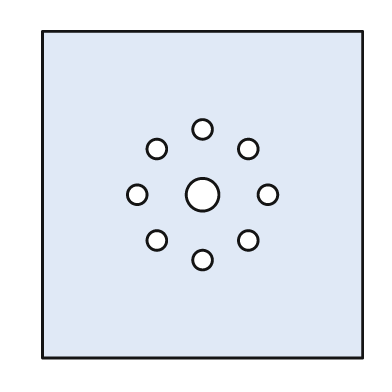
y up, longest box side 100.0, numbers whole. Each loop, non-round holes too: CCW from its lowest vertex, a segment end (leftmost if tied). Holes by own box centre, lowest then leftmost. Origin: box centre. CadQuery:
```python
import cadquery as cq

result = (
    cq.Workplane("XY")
    .moveTo(-49.0, -50.0)
    .lineTo(49.0, -50.0)
    .lineTo(49.0, 50.0)
    .lineTo(-49.0, 50.0)
    .close()
    .moveTo(0.0, -20.0)
    .circle(3.0)
    .moveTo(-14.0, -14.0)
    .circle(3.0)
    .moveTo(14.0, -14.0)
    .circle(3.0)
    .moveTo(-20.0, 0.0)
    .circle(3.0)
    .moveTo(0.0, 0.0)
    .circle(5.0)
    .moveTo(20.0, 0.0)
    .circle(3.0)
    .moveTo(-14.0, 14.0)
    .circle(3.0)
    .moveTo(14.0, 14.0)
    .circle(3.0)
    .moveTo(0.0, 20.0)
    .circle(3.0)
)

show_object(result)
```